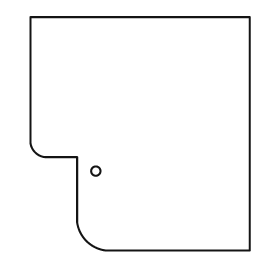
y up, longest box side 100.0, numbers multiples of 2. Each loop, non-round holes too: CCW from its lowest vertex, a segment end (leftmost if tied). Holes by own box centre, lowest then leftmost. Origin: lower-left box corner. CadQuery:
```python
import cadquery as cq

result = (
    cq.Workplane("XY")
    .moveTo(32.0, 0.0)
    .lineTo(94.0, 0.0)
    .lineTo(94.0, 100.0)
    .lineTo(0.0, 100.0)
    .lineTo(0.0, 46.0)
    .threePointArc((2.0, 42.0), (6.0, 40.0))
    .lineTo(20.0, 40.0)
    .lineTo(20.0, 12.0)
    .threePointArc((24.0, 4.0), (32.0, 0.0))
    .close()
    .moveTo(28.0, 34.0)
    .circle(2.0)
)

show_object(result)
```